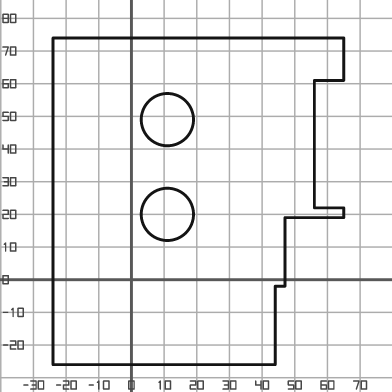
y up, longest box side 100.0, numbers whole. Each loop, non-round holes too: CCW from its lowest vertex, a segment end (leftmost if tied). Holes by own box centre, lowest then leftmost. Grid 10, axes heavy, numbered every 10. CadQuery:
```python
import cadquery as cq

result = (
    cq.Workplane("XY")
    .moveTo(-24.0, -26.0)
    .lineTo(44.0, -26.0)
    .lineTo(44.0, -2.0)
    .lineTo(47.0, -2.0)
    .lineTo(47.0, 19.0)
    .lineTo(65.0, 19.0)
    .lineTo(65.0, 22.0)
    .lineTo(56.0, 22.0)
    .lineTo(56.0, 61.0)
    .lineTo(65.0, 61.0)
    .lineTo(65.0, 74.0)
    .lineTo(-24.0, 74.0)
    .close()
    .moveTo(11.0, 20.0)
    .circle(8.0)
    .moveTo(11.0, 49.0)
    .circle(8.0)
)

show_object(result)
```